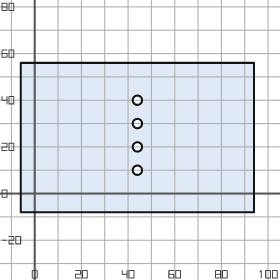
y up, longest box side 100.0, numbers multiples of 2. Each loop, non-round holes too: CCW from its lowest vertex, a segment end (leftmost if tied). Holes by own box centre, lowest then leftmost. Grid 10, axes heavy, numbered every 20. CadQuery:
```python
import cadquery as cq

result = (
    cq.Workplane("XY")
    .moveTo(-6.0, -8.0)
    .lineTo(94.0, -8.0)
    .lineTo(94.0, 56.0)
    .lineTo(-6.0, 56.0)
    .close()
    .moveTo(44.0, 10.0)
    .circle(2.0)
    .moveTo(44.0, 20.0)
    .circle(2.0)
    .moveTo(44.0, 30.0)
    .circle(2.0)
    .moveTo(44.0, 40.0)
    .circle(2.0)
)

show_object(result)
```